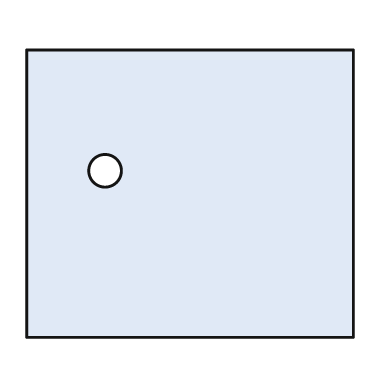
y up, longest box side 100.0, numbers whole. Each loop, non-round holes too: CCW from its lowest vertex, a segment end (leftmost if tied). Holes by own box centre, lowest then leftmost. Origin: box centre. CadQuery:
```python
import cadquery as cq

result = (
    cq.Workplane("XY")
    .moveTo(-50.0, -44.0)
    .lineTo(50.0, -44.0)
    .lineTo(50.0, 44.0)
    .lineTo(-50.0, 44.0)
    .close()
    .moveTo(-26.0, 7.0)
    .circle(5.0)
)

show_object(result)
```